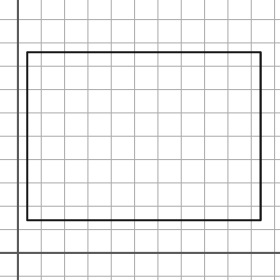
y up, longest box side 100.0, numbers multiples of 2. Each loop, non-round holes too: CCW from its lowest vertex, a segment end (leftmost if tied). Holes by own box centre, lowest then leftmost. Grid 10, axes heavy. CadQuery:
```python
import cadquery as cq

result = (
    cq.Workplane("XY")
    .moveTo(4.0, 14.0)
    .lineTo(104.0, 14.0)
    .lineTo(104.0, 86.0)
    .lineTo(4.0, 86.0)
    .close()
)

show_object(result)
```